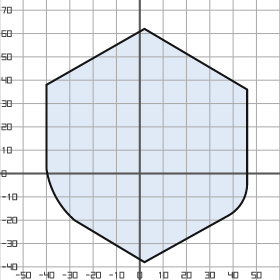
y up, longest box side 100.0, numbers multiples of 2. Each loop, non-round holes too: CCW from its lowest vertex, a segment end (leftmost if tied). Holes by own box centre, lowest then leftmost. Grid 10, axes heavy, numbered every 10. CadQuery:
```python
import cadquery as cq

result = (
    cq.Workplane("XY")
    .moveTo(2.0, -38.0)
    .lineTo(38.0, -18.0)
    .threePointArc((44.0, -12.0), (46.0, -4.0))
    .lineTo(46.0, 36.0)
    .lineTo(2.0, 62.0)
    .lineTo(-40.0, 38.0)
    .lineTo(-40.0, 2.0)
    .threePointArc((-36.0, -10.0), (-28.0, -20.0))
    .close()
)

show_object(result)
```